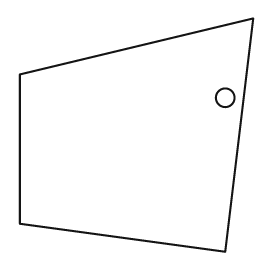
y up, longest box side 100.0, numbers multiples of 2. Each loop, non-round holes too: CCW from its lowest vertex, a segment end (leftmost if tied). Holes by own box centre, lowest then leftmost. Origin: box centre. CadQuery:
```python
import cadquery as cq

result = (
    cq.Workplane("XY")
    .moveTo(38.0, -50.0)
    .lineTo(50.0, 50.0)
    .lineTo(-50.0, 26.0)
    .lineTo(-50.0, -38.0)
    .close()
    .moveTo(38.0, 16.0)
    .circle(4.0)
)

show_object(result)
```